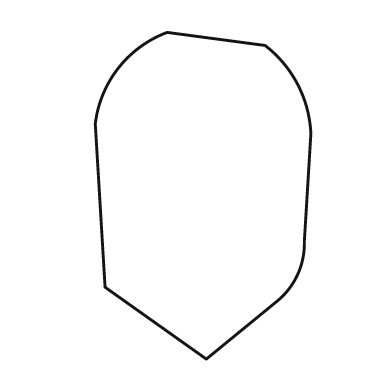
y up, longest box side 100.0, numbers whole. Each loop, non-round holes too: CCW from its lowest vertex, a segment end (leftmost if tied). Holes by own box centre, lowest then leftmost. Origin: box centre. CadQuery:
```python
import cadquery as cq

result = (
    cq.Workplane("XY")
    .moveTo(1.0, -50.0)
    .lineTo(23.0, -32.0)
    .threePointArc((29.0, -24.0), (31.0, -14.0))
    .lineTo(33.0, 19.0)
    .threePointArc((29.0, 34.0), (19.0, 46.0))
    .lineTo(-11.0, 50.0)
    .threePointArc((-26.0, 39.0), (-33.0, 22.0))
    .lineTo(-30.0, -28.0)
    .close()
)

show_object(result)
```